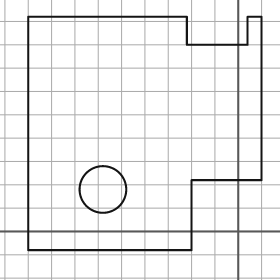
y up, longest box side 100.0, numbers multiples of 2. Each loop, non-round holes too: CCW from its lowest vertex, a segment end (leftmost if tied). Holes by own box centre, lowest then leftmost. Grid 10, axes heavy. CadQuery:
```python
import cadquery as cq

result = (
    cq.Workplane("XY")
    .moveTo(-90.0, -8.0)
    .lineTo(-20.0, -8.0)
    .lineTo(-20.0, 22.0)
    .lineTo(10.0, 22.0)
    .lineTo(10.0, 92.0)
    .lineTo(4.0, 92.0)
    .lineTo(4.0, 80.0)
    .lineTo(-22.0, 80.0)
    .lineTo(-22.0, 92.0)
    .lineTo(-90.0, 92.0)
    .close()
    .moveTo(-58.0, 18.0)
    .circle(10.0)
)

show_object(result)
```